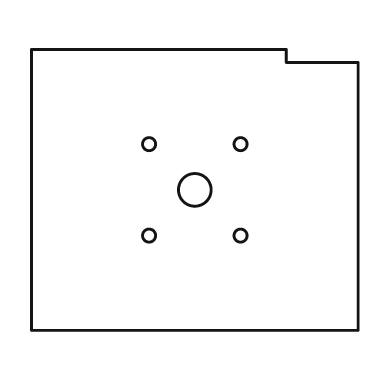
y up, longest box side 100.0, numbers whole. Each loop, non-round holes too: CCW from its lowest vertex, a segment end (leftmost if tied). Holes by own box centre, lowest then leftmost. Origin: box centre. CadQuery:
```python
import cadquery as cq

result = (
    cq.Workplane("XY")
    .moveTo(-50.0, -43.0)
    .lineTo(50.0, -43.0)
    .lineTo(50.0, 39.0)
    .lineTo(28.0, 39.0)
    .lineTo(28.0, 43.0)
    .lineTo(-50.0, 43.0)
    .close()
    .moveTo(-14.0, -14.0)
    .circle(2.0)
    .moveTo(14.0, -14.0)
    .circle(2.0)
    .moveTo(0.0, 0.0)
    .circle(5.0)
    .moveTo(-14.0, 14.0)
    .circle(2.0)
    .moveTo(14.0, 14.0)
    .circle(2.0)
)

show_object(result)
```